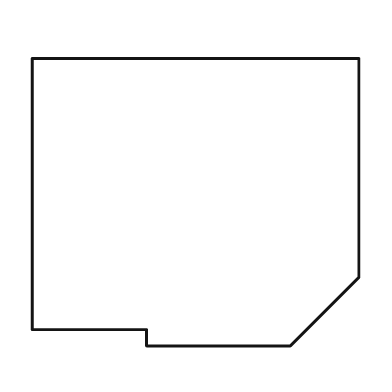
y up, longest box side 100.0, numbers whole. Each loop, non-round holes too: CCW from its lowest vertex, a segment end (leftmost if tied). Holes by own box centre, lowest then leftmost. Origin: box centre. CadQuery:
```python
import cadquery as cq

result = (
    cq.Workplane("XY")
    .moveTo(-15.0, -44.0)
    .lineTo(29.0, -44.0)
    .lineTo(50.0, -23.0)
    .lineTo(50.0, 44.0)
    .lineTo(-50.0, 44.0)
    .lineTo(-50.0, -39.0)
    .lineTo(-15.0, -39.0)
    .close()
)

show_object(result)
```